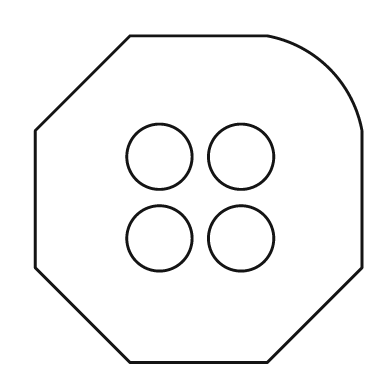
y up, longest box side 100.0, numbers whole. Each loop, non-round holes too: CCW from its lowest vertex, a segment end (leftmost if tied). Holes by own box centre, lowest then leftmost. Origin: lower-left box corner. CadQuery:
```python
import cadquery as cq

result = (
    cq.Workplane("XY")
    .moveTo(29.0, 0.0)
    .lineTo(71.0, 0.0)
    .lineTo(100.0, 29.0)
    .lineTo(100.0, 71.0)
    .threePointArc((90.0, 90.0), (71.0, 100.0))
    .lineTo(29.0, 100.0)
    .lineTo(0.0, 71.0)
    .lineTo(0.0, 29.0)
    .close()
    .moveTo(38.0, 38.0)
    .circle(10.0)
    .moveTo(63.0, 38.0)
    .circle(10.0)
    .moveTo(38.0, 63.0)
    .circle(10.0)
    .moveTo(63.0, 63.0)
    .circle(10.0)
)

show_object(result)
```